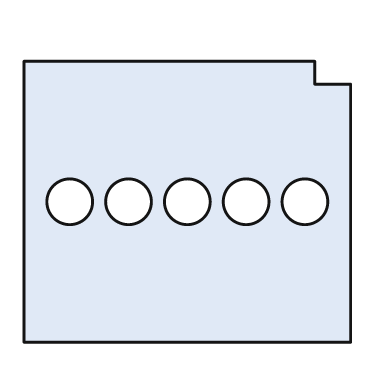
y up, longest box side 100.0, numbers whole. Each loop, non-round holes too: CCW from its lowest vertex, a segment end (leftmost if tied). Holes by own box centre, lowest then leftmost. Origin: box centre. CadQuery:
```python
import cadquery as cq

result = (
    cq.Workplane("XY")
    .moveTo(-50.0, -43.0)
    .lineTo(50.0, -43.0)
    .lineTo(50.0, 36.0)
    .lineTo(39.0, 36.0)
    .lineTo(39.0, 43.0)
    .lineTo(-50.0, 43.0)
    .close()
    .moveTo(-36.0, 0.0)
    .circle(7.0)
    .moveTo(-18.0, 0.0)
    .circle(7.0)
    .moveTo(0.0, 0.0)
    .circle(7.0)
    .moveTo(18.0, 0.0)
    .circle(7.0)
    .moveTo(36.0, 0.0)
    .circle(7.0)
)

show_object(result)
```